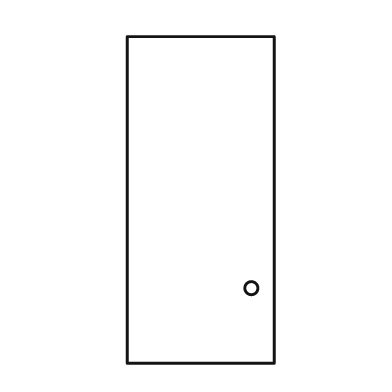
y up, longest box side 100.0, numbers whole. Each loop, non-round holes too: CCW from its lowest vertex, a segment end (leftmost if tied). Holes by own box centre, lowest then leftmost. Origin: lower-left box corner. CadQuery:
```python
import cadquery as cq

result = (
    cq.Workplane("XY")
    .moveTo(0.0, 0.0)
    .lineTo(45.0, 0.0)
    .lineTo(45.0, 100.0)
    .lineTo(0.0, 100.0)
    .close()
    .moveTo(38.0, 23.0)
    .circle(2.0)
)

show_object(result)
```